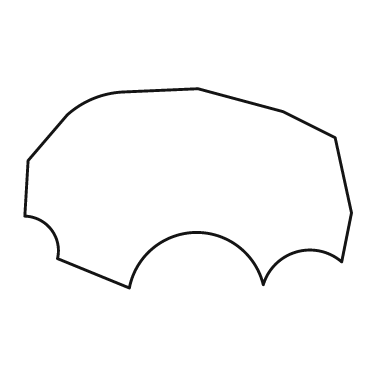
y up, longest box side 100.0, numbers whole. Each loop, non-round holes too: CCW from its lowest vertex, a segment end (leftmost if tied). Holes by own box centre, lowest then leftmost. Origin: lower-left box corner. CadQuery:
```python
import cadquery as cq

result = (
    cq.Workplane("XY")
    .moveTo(32.0, 0.0)
    .threePointArc((52.0, 17.0), (73.0, 1.0))
    .threePointArc((83.0, 11.0), (97.0, 8.0))
    .lineTo(100.0, 23.0)
    .lineTo(95.0, 46.0)
    .lineTo(79.0, 54.0)
    .lineTo(53.0, 61.0)
    .lineTo(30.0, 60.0)
    .threePointArc((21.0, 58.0), (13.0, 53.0))
    .lineTo(1.0, 39.0)
    .lineTo(0.0, 22.0)
    .threePointArc((8.0, 18.0), (10.0, 9.0))
    .close()
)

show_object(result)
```